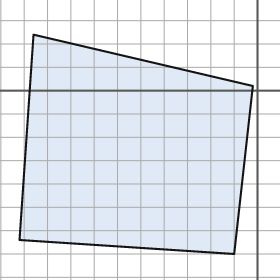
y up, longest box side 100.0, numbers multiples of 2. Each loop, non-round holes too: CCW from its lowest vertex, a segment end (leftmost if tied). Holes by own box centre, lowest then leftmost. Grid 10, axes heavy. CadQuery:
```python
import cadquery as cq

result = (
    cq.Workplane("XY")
    .moveTo(-10.0, -70.0)
    .lineTo(-2.0, 2.0)
    .lineTo(-96.0, 24.0)
    .lineTo(-102.0, -64.0)
    .close()
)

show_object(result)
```